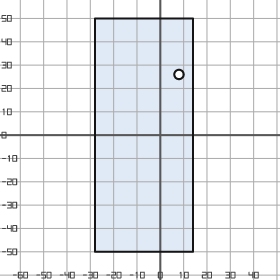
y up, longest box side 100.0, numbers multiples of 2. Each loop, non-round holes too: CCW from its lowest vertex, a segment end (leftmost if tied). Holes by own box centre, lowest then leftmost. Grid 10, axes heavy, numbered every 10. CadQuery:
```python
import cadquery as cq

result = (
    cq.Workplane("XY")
    .moveTo(-28.0, -50.0)
    .lineTo(14.0, -50.0)
    .lineTo(14.0, 50.0)
    .lineTo(-28.0, 50.0)
    .close()
    .moveTo(8.0, 26.0)
    .circle(2.0)
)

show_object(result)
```